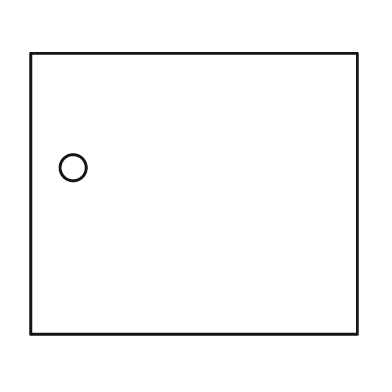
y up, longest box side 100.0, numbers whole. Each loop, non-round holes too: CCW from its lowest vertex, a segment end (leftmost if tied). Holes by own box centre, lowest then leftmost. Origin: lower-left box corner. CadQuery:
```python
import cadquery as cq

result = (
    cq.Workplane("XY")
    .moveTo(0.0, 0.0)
    .lineTo(100.0, 0.0)
    .lineTo(100.0, 86.0)
    .lineTo(0.0, 86.0)
    .close()
    .moveTo(13.0, 51.0)
    .circle(4.0)
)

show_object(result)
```